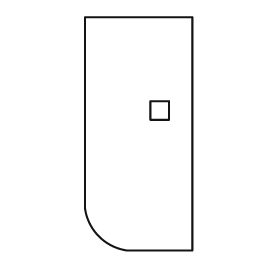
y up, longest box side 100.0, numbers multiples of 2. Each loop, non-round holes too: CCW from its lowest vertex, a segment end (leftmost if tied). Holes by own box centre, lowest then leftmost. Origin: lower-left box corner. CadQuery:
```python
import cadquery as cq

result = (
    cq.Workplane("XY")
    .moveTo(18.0, 0.0)
    .lineTo(46.0, 0.0)
    .lineTo(46.0, 100.0)
    .lineTo(0.0, 100.0)
    .lineTo(0.0, 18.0)
    .threePointArc((6.0, 6.0), (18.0, 0.0))
    .close()
    .moveTo(28.0, 56.0)
    .lineTo(36.0, 56.0)
    .lineTo(36.0, 64.0)
    .lineTo(28.0, 64.0)
    .close()
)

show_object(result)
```